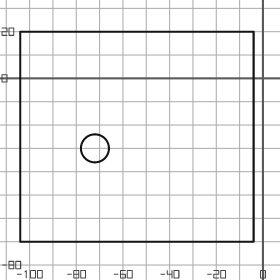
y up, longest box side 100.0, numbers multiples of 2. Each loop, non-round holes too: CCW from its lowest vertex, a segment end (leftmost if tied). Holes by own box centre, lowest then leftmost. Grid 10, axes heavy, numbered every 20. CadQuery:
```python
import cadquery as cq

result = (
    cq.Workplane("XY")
    .moveTo(-104.0, -70.0)
    .lineTo(-4.0, -70.0)
    .lineTo(-4.0, 20.0)
    .lineTo(-104.0, 20.0)
    .close()
    .moveTo(-72.0, -30.0)
    .circle(6.0)
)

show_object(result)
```